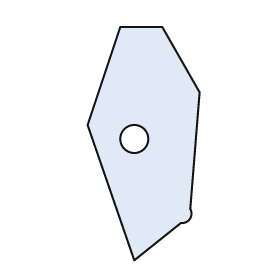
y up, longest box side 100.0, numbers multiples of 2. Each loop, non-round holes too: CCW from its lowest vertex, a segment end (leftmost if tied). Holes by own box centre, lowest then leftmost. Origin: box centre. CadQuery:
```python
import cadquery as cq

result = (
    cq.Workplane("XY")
    .moveTo(-4.0, -50.0)
    .lineTo(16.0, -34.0)
    .threePointArc((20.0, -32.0), (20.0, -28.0))
    .lineTo(24.0, 22.0)
    .lineTo(8.0, 50.0)
    .lineTo(-10.0, 50.0)
    .lineTo(-24.0, 8.0)
    .close()
    .moveTo(-4.0, 2.0)
    .circle(6.0)
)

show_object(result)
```